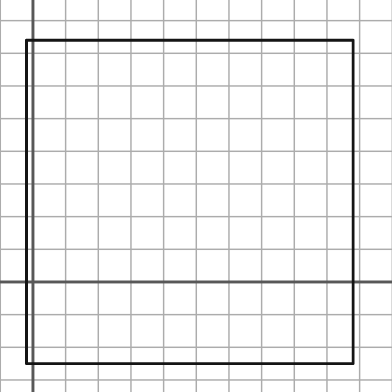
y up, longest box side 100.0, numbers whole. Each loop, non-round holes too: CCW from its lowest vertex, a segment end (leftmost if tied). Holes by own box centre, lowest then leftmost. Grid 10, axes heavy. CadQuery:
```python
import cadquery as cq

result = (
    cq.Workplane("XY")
    .moveTo(-2.0, -25.0)
    .lineTo(98.0, -25.0)
    .lineTo(98.0, 74.0)
    .lineTo(-2.0, 74.0)
    .close()
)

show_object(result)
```